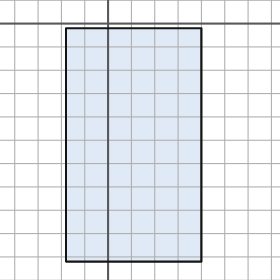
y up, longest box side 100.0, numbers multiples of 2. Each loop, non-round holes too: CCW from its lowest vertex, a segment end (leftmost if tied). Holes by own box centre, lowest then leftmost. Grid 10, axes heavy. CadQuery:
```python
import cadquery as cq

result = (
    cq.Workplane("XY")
    .moveTo(-18.0, -102.0)
    .lineTo(40.0, -102.0)
    .lineTo(40.0, -2.0)
    .lineTo(-18.0, -2.0)
    .close()
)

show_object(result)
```